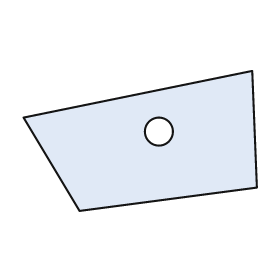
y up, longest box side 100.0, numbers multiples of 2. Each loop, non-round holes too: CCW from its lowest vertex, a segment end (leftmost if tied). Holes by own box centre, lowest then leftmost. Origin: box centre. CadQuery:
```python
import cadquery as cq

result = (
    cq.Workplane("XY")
    .moveTo(-26.0, -30.0)
    .lineTo(50.0, -20.0)
    .lineTo(48.0, 30.0)
    .lineTo(-50.0, 10.0)
    .close()
    .moveTo(8.0, 4.0)
    .circle(6.0)
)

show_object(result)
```